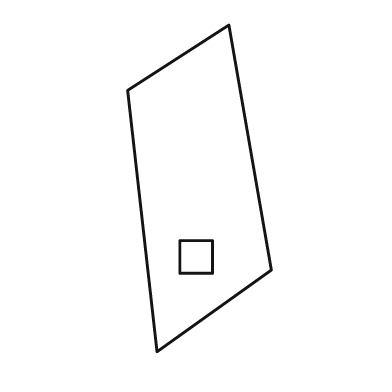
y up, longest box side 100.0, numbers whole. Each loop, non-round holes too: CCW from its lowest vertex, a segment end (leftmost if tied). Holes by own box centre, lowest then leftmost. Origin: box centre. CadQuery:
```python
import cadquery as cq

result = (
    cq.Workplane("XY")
    .moveTo(-13.0, -50.0)
    .lineTo(22.0, -25.0)
    .lineTo(9.0, 50.0)
    .lineTo(-22.0, 30.0)
    .close()
    .moveTo(-6.0, -26.0)
    .lineTo(4.0, -26.0)
    .lineTo(4.0, -16.0)
    .lineTo(-6.0, -16.0)
    .close()
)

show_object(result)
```